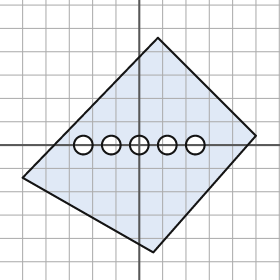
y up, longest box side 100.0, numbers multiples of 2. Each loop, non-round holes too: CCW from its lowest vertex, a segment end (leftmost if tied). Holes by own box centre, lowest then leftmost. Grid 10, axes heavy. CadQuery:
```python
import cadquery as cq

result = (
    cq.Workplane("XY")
    .moveTo(6.0, -46.0)
    .lineTo(50.0, 4.0)
    .lineTo(8.0, 46.0)
    .lineTo(-50.0, -14.0)
    .close()
    .moveTo(-24.0, 0.0)
    .circle(4.0)
    .moveTo(-12.0, 0.0)
    .circle(4.0)
    .moveTo(0.0, 0.0)
    .circle(4.0)
    .moveTo(12.0, 0.0)
    .circle(4.0)
    .moveTo(24.0, 0.0)
    .circle(4.0)
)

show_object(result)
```